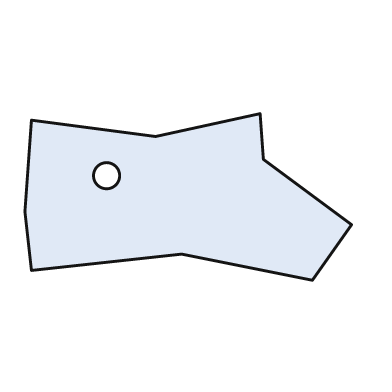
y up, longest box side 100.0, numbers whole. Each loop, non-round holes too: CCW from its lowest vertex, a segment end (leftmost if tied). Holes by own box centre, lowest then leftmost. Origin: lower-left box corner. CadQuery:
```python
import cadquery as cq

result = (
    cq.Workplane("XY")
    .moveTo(88.0, 0.0)
    .lineTo(100.0, 17.0)
    .lineTo(73.0, 37.0)
    .lineTo(72.0, 51.0)
    .lineTo(40.0, 44.0)
    .lineTo(2.0, 49.0)
    .lineTo(0.0, 21.0)
    .lineTo(2.0, 3.0)
    .lineTo(48.0, 8.0)
    .close()
    .moveTo(25.0, 32.0)
    .circle(4.0)
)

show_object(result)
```